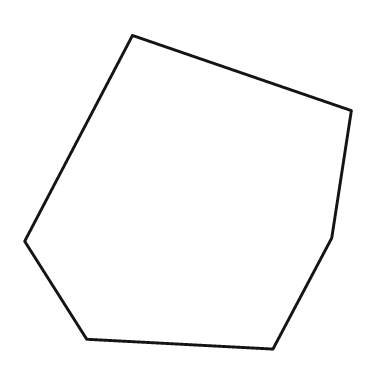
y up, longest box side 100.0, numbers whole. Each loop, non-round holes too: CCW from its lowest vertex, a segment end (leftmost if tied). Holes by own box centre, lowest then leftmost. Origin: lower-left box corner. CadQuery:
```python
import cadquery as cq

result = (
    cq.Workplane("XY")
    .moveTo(76.0, 0.0)
    .lineTo(94.0, 34.0)
    .lineTo(100.0, 73.0)
    .lineTo(33.0, 96.0)
    .lineTo(0.0, 33.0)
    .lineTo(19.0, 3.0)
    .close()
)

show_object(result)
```